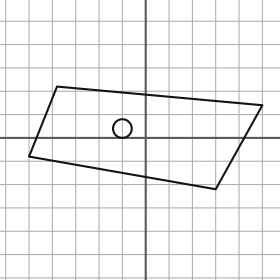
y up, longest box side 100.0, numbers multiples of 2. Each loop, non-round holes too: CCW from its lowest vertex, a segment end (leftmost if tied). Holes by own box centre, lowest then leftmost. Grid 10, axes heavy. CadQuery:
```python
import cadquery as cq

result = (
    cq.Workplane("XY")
    .moveTo(30.0, -22.0)
    .lineTo(50.0, 14.0)
    .lineTo(-38.0, 22.0)
    .lineTo(-50.0, -8.0)
    .close()
    .moveTo(-10.0, 4.0)
    .circle(4.0)
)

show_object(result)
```